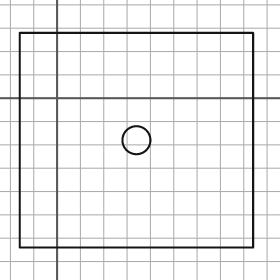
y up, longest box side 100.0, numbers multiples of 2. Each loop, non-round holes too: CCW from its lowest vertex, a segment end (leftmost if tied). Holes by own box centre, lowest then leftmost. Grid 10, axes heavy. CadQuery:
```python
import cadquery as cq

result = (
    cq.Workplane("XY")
    .moveTo(-16.0, -64.0)
    .lineTo(84.0, -64.0)
    .lineTo(84.0, 28.0)
    .lineTo(-16.0, 28.0)
    .close()
    .moveTo(34.0, -18.0)
    .circle(6.0)
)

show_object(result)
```